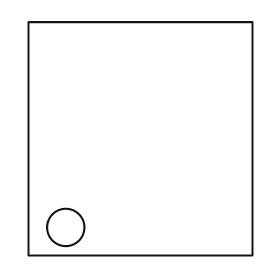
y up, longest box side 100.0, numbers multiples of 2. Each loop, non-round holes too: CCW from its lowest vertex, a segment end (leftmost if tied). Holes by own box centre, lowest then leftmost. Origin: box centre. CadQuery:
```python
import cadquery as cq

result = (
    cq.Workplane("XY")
    .moveTo(-48.0, -50.0)
    .lineTo(48.0, -50.0)
    .lineTo(48.0, 50.0)
    .lineTo(-48.0, 50.0)
    .close()
    .moveTo(-32.0, -38.0)
    .circle(8.0)
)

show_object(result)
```